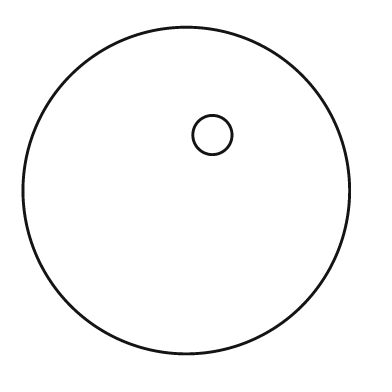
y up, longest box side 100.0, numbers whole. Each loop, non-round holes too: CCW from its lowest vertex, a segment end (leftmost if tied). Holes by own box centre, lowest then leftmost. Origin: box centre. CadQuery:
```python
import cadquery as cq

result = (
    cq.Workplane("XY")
    .moveTo(0.0, 0.0)
    .circle(50.0)
    .moveTo(8.0, 17.0)
    .circle(6.0)
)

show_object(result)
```